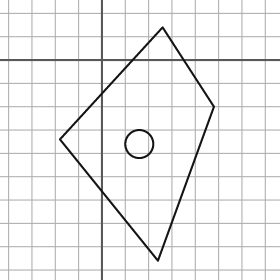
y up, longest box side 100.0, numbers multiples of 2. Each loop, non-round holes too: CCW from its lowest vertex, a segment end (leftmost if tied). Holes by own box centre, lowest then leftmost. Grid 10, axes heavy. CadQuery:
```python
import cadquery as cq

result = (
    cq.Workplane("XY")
    .moveTo(24.0, -86.0)
    .lineTo(48.0, -20.0)
    .lineTo(26.0, 14.0)
    .lineTo(-18.0, -34.0)
    .close()
    .moveTo(16.0, -36.0)
    .circle(6.0)
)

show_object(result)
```